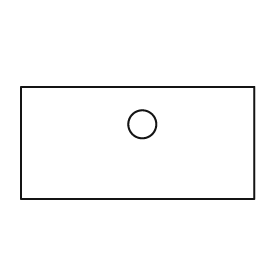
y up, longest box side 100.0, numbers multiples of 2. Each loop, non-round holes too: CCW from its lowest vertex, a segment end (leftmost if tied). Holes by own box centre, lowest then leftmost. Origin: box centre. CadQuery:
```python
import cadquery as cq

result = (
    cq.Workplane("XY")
    .moveTo(-50.0, -24.0)
    .lineTo(50.0, -24.0)
    .lineTo(50.0, 24.0)
    .lineTo(-50.0, 24.0)
    .close()
    .moveTo(2.0, 8.0)
    .circle(6.0)
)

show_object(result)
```